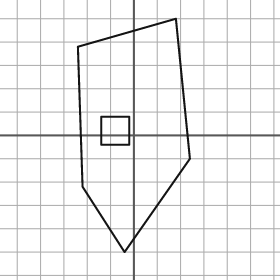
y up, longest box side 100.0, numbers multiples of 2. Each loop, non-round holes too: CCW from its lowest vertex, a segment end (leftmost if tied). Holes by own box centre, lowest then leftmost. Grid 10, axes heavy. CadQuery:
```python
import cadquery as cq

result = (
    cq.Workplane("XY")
    .moveTo(-4.0, -50.0)
    .lineTo(24.0, -10.0)
    .lineTo(18.0, 50.0)
    .lineTo(-24.0, 38.0)
    .lineTo(-22.0, -22.0)
    .close()
    .moveTo(-14.0, -4.0)
    .lineTo(-2.0, -4.0)
    .lineTo(-2.0, 8.0)
    .lineTo(-14.0, 8.0)
    .close()
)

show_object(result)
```